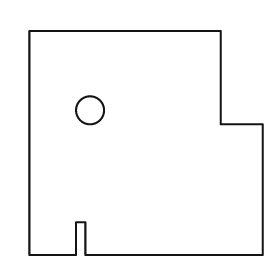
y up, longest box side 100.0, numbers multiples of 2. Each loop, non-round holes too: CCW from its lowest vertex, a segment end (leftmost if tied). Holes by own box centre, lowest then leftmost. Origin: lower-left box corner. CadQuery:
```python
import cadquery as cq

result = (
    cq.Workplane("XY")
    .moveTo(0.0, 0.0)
    .lineTo(20.0, 0.0)
    .lineTo(20.0, 14.0)
    .lineTo(24.0, 14.0)
    .lineTo(24.0, 0.0)
    .lineTo(100.0, 0.0)
    .lineTo(100.0, 56.0)
    .lineTo(82.0, 56.0)
    .lineTo(82.0, 96.0)
    .lineTo(0.0, 96.0)
    .close()
    .moveTo(26.0, 62.0)
    .circle(6.0)
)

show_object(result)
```